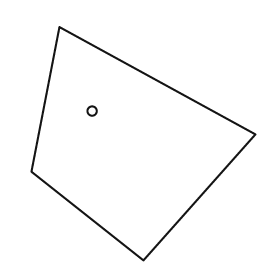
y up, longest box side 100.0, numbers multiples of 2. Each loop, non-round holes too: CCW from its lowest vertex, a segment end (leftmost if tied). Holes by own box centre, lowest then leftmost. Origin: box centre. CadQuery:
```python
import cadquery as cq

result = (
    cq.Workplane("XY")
    .moveTo(0.0, -50.0)
    .lineTo(48.0, 4.0)
    .lineTo(-36.0, 50.0)
    .lineTo(-48.0, -12.0)
    .close()
    .moveTo(-22.0, 14.0)
    .circle(2.0)
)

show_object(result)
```